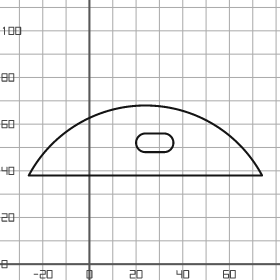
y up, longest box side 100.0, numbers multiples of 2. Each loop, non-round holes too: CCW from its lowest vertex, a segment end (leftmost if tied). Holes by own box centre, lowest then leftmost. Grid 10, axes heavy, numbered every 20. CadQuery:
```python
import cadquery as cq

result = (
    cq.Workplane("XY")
    .moveTo(-26.0, 38.0)
    .lineTo(74.0, 38.0)
    .threePointArc((24.0, 68.0), (-26.0, 38.0))
    .close()
    .moveTo(24.0, 48.0)
    .lineTo(32.0, 48.0)
    .threePointArc((36.0, 52.0), (32.0, 56.0))
    .lineTo(24.0, 56.0)
    .threePointArc((20.0, 52.0), (24.0, 48.0))
    .close()
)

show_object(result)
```